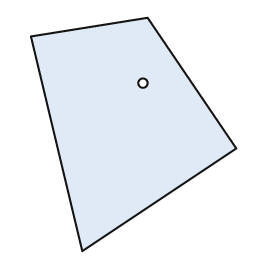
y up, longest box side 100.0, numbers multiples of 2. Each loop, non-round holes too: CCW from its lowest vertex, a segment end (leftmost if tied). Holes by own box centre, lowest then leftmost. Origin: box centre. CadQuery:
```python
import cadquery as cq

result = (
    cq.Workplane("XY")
    .moveTo(-22.0, -50.0)
    .lineTo(44.0, -6.0)
    .lineTo(6.0, 50.0)
    .lineTo(-44.0, 42.0)
    .close()
    .moveTo(4.0, 22.0)
    .circle(2.0)
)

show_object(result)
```